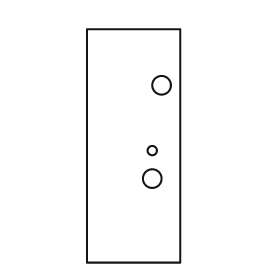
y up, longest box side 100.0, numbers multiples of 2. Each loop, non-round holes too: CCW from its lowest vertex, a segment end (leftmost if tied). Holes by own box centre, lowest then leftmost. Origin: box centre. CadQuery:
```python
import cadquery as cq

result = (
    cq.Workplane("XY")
    .moveTo(-20.0, -50.0)
    .lineTo(20.0, -50.0)
    .lineTo(20.0, 50.0)
    .lineTo(-20.0, 50.0)
    .close()
    .moveTo(8.0, -14.0)
    .circle(4.0)
    .moveTo(8.0, -2.0)
    .circle(2.0)
    .moveTo(12.0, 26.0)
    .circle(4.0)
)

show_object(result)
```